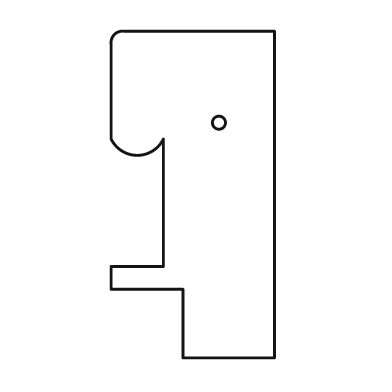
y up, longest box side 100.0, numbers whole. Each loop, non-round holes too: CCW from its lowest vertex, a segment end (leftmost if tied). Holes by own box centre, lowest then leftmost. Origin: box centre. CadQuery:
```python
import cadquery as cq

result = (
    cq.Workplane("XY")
    .moveTo(-3.0, -50.0)
    .lineTo(25.0, -50.0)
    .lineTo(25.0, 50.0)
    .lineTo(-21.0, 50.0)
    .threePointArc((-24.0, 49.0), (-25.0, 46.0))
    .lineTo(-25.0, 17.0)
    .threePointArc((-17.0, 12.0), (-9.0, 17.0))
    .lineTo(-9.0, -22.0)
    .lineTo(-25.0, -22.0)
    .lineTo(-25.0, -29.0)
    .lineTo(-3.0, -29.0)
    .close()
    .moveTo(8.0, 22.0)
    .circle(2.0)
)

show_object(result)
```